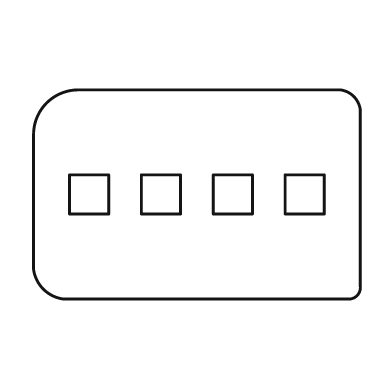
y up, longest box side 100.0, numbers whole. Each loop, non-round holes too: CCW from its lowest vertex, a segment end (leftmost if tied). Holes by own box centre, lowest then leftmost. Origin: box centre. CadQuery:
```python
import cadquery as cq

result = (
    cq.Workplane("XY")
    .moveTo(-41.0, -32.0)
    .lineTo(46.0, -32.0)
    .threePointArc((49.0, -31.0), (50.0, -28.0))
    .lineTo(50.0, 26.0)
    .threePointArc((48.0, 30.0), (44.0, 32.0))
    .lineTo(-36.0, 32.0)
    .threePointArc((-46.0, 28.0), (-50.0, 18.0))
    .lineTo(-50.0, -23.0)
    .threePointArc((-47.0, -29.0), (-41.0, -32.0))
    .close()
    .moveTo(-39.0, -6.0)
    .lineTo(-27.0, -6.0)
    .lineTo(-27.0, 6.0)
    .lineTo(-39.0, 6.0)
    .close()
    .moveTo(-17.0, -6.0)
    .lineTo(-5.0, -6.0)
    .lineTo(-5.0, 6.0)
    .lineTo(-17.0, 6.0)
    .close()
    .moveTo(5.0, -6.0)
    .lineTo(17.0, -6.0)
    .lineTo(17.0, 6.0)
    .lineTo(5.0, 6.0)
    .close()
    .moveTo(27.0, -6.0)
    .lineTo(39.0, -6.0)
    .lineTo(39.0, 6.0)
    .lineTo(27.0, 6.0)
    .close()
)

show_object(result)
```